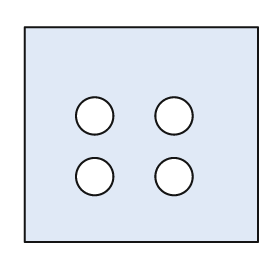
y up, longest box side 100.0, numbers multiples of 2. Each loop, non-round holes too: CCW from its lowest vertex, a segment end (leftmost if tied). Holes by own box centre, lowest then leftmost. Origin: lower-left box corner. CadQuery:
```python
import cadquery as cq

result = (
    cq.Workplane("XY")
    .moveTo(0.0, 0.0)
    .lineTo(100.0, 0.0)
    .lineTo(100.0, 92.0)
    .lineTo(0.0, 92.0)
    .close()
    .moveTo(30.0, 28.0)
    .circle(8.0)
    .moveTo(64.0, 28.0)
    .circle(8.0)
    .moveTo(30.0, 54.0)
    .circle(8.0)
    .moveTo(64.0, 54.0)
    .circle(8.0)
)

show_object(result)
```